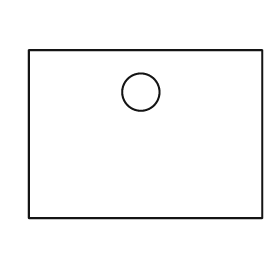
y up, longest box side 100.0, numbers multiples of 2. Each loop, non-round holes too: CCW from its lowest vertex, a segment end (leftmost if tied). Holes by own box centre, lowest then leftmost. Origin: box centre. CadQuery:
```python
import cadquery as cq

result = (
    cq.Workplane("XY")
    .moveTo(-50.0, -36.0)
    .lineTo(50.0, -36.0)
    .lineTo(50.0, 36.0)
    .lineTo(-50.0, 36.0)
    .close()
    .moveTo(-2.0, 18.0)
    .circle(8.0)
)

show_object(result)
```